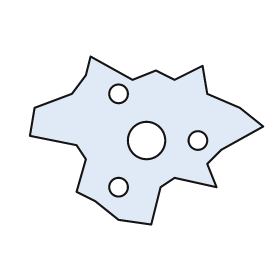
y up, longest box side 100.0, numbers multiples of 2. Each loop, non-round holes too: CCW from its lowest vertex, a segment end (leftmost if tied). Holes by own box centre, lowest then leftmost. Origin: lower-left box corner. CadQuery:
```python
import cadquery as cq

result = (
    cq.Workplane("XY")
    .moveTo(52.0, 0.0)
    .lineTo(56.0, 16.0)
    .lineTo(62.0, 20.0)
    .lineTo(80.0, 16.0)
    .lineTo(76.0, 26.0)
    .lineTo(82.0, 32.0)
    .lineTo(100.0, 42.0)
    .lineTo(90.0, 50.0)
    .lineTo(76.0, 56.0)
    .lineTo(74.0, 68.0)
    .lineTo(62.0, 62.0)
    .lineTo(54.0, 66.0)
    .lineTo(44.0, 62.0)
    .lineTo(26.0, 72.0)
    .lineTo(24.0, 64.0)
    .lineTo(18.0, 56.0)
    .lineTo(2.0, 50.0)
    .lineTo(0.0, 38.0)
    .lineTo(20.0, 34.0)
    .lineTo(24.0, 28.0)
    .lineTo(20.0, 14.0)
    .lineTo(28.0, 10.0)
    .lineTo(38.0, 2.0)
    .close()
    .moveTo(38.0, 16.0)
    .circle(4.0)
    .moveTo(50.0, 36.0)
    .circle(8.0)
    .moveTo(72.0, 36.0)
    .circle(4.0)
    .moveTo(38.0, 56.0)
    .circle(4.0)
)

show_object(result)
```